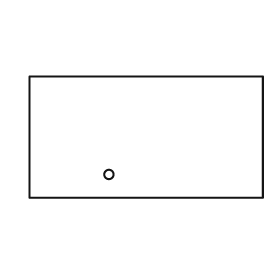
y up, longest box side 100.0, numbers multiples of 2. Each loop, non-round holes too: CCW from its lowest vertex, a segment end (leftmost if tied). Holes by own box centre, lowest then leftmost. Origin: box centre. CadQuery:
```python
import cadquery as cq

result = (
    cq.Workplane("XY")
    .moveTo(-50.0, -26.0)
    .lineTo(50.0, -26.0)
    .lineTo(50.0, 26.0)
    .lineTo(-50.0, 26.0)
    .close()
    .moveTo(-16.0, -16.0)
    .circle(2.0)
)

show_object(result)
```